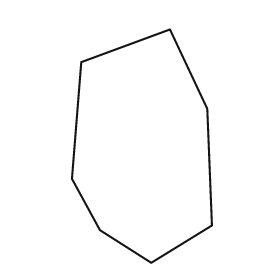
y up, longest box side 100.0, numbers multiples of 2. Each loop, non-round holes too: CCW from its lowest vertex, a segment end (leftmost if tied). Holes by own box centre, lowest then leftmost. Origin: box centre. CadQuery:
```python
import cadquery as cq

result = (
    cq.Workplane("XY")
    .moveTo(4.0, -50.0)
    .lineTo(30.0, -34.0)
    .lineTo(28.0, 16.0)
    .lineTo(12.0, 50.0)
    .lineTo(-26.0, 36.0)
    .lineTo(-30.0, -14.0)
    .lineTo(-18.0, -36.0)
    .close()
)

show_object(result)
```